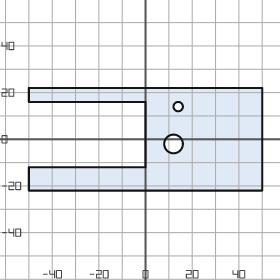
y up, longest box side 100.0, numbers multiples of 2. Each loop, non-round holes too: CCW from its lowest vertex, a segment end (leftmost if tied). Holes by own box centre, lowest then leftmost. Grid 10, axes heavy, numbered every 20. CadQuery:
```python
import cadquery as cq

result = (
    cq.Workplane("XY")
    .moveTo(-50.0, -22.0)
    .lineTo(50.0, -22.0)
    .lineTo(50.0, 22.0)
    .lineTo(-50.0, 22.0)
    .lineTo(-50.0, 16.0)
    .lineTo(0.0, 16.0)
    .lineTo(0.0, -12.0)
    .lineTo(-50.0, -12.0)
    .close()
    .moveTo(12.0, -2.0)
    .circle(4.0)
    .moveTo(14.0, 14.0)
    .circle(2.0)
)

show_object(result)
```